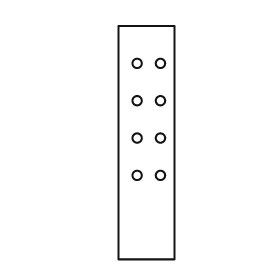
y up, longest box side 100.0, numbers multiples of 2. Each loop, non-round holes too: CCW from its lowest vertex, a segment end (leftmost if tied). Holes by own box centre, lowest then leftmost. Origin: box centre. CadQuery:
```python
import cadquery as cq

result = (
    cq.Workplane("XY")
    .moveTo(-12.0, -50.0)
    .lineTo(12.0, -50.0)
    .lineTo(12.0, 50.0)
    .lineTo(-12.0, 50.0)
    .close()
    .moveTo(-4.0, -14.0)
    .circle(2.0)
    .moveTo(6.0, -14.0)
    .circle(2.0)
    .moveTo(-4.0, 2.0)
    .circle(2.0)
    .moveTo(6.0, 2.0)
    .circle(2.0)
    .moveTo(-4.0, 18.0)
    .circle(2.0)
    .moveTo(6.0, 18.0)
    .circle(2.0)
    .moveTo(-4.0, 34.0)
    .circle(2.0)
    .moveTo(6.0, 34.0)
    .circle(2.0)
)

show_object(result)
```